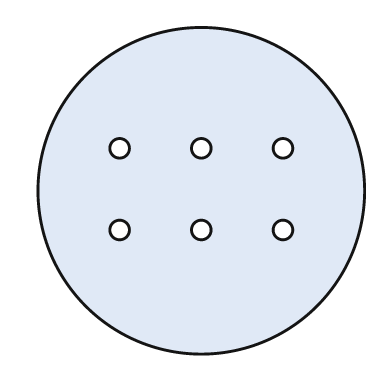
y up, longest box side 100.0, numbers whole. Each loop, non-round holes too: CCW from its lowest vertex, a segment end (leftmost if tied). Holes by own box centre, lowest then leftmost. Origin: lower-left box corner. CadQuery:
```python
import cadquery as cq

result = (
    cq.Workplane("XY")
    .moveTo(50.0, 50.0)
    .circle(50.0)
    .moveTo(25.0, 38.0)
    .circle(3.0)
    .moveTo(50.0, 38.0)
    .circle(3.0)
    .moveTo(75.0, 38.0)
    .circle(3.0)
    .moveTo(25.0, 63.0)
    .circle(3.0)
    .moveTo(50.0, 63.0)
    .circle(3.0)
    .moveTo(75.0, 63.0)
    .circle(3.0)
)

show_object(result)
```